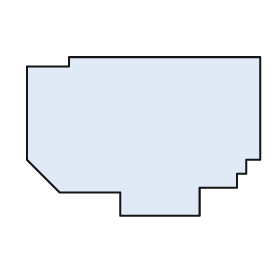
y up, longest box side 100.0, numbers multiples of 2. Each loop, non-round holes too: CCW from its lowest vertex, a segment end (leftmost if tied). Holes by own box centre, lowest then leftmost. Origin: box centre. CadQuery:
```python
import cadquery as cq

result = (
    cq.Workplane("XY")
    .moveTo(-10.0, -34.0)
    .lineTo(24.0, -34.0)
    .lineTo(24.0, -22.0)
    .lineTo(40.0, -22.0)
    .lineTo(40.0, -16.0)
    .lineTo(44.0, -16.0)
    .lineTo(44.0, -10.0)
    .lineTo(50.0, -10.0)
    .lineTo(50.0, 34.0)
    .lineTo(-32.0, 34.0)
    .lineTo(-32.0, 30.0)
    .lineTo(-50.0, 30.0)
    .lineTo(-50.0, -10.0)
    .lineTo(-36.0, -24.0)
    .lineTo(-10.0, -24.0)
    .close()
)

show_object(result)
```